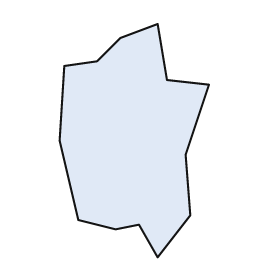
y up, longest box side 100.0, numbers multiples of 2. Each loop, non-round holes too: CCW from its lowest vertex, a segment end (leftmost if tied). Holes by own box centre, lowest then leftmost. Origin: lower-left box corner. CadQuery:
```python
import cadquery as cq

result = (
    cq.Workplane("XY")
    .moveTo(42.0, 0.0)
    .lineTo(56.0, 18.0)
    .lineTo(54.0, 44.0)
    .lineTo(64.0, 74.0)
    .lineTo(46.0, 76.0)
    .lineTo(42.0, 100.0)
    .lineTo(26.0, 94.0)
    .lineTo(16.0, 84.0)
    .lineTo(2.0, 82.0)
    .lineTo(0.0, 50.0)
    .lineTo(8.0, 16.0)
    .lineTo(24.0, 12.0)
    .lineTo(34.0, 14.0)
    .close()
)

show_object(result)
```